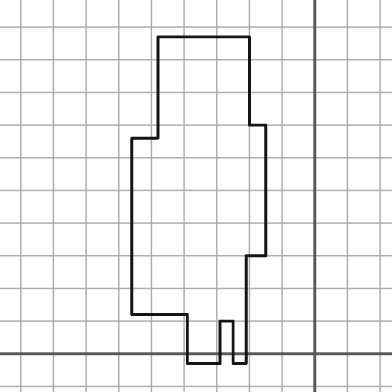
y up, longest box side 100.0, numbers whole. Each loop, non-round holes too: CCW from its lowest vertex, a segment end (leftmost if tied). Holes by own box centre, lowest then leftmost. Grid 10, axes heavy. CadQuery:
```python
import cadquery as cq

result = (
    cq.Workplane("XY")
    .moveTo(-39.0, -3.0)
    .lineTo(-29.0, -3.0)
    .lineTo(-29.0, 10.0)
    .lineTo(-25.0, 10.0)
    .lineTo(-25.0, -3.0)
    .lineTo(-21.0, -3.0)
    .lineTo(-21.0, 30.0)
    .lineTo(-15.0, 30.0)
    .lineTo(-15.0, 70.0)
    .lineTo(-20.0, 70.0)
    .lineTo(-20.0, 97.0)
    .lineTo(-48.0, 97.0)
    .lineTo(-48.0, 66.0)
    .lineTo(-56.0, 66.0)
    .lineTo(-56.0, 12.0)
    .lineTo(-39.0, 12.0)
    .close()
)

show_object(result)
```